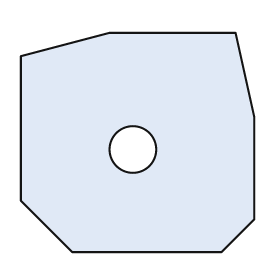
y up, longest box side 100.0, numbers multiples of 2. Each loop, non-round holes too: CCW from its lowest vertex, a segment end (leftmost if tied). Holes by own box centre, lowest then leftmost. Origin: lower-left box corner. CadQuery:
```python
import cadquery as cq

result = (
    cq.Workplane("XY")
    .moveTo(22.0, 0.0)
    .lineTo(86.0, 0.0)
    .lineTo(100.0, 14.0)
    .lineTo(100.0, 58.0)
    .lineTo(92.0, 94.0)
    .lineTo(38.0, 94.0)
    .lineTo(0.0, 84.0)
    .lineTo(0.0, 22.0)
    .close()
    .moveTo(48.0, 44.0)
    .circle(10.0)
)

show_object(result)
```